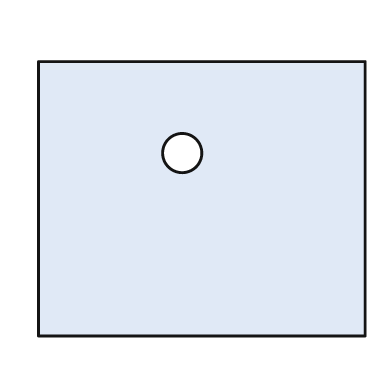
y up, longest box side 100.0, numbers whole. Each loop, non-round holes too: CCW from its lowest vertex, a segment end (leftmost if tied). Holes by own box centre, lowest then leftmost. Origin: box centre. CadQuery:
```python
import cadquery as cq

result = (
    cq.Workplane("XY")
    .moveTo(-50.0, -42.0)
    .lineTo(50.0, -42.0)
    .lineTo(50.0, 42.0)
    .lineTo(-50.0, 42.0)
    .close()
    .moveTo(-6.0, 14.0)
    .circle(6.0)
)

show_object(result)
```